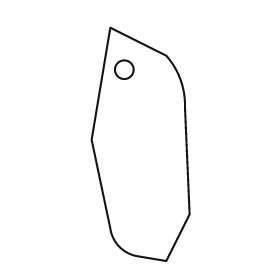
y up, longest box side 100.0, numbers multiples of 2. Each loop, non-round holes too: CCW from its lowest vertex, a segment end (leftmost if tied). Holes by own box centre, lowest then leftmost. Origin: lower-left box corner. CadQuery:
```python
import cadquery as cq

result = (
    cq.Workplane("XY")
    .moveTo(32.0, 0.0)
    .lineTo(42.0, 20.0)
    .lineTo(40.0, 66.0)
    .threePointArc((38.0, 78.0), (32.0, 88.0))
    .lineTo(8.0, 100.0)
    .lineTo(0.0, 52.0)
    .lineTo(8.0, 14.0)
    .threePointArc((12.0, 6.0), (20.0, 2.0))
    .close()
    .moveTo(14.0, 82.0)
    .circle(4.0)
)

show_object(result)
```